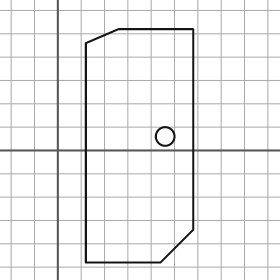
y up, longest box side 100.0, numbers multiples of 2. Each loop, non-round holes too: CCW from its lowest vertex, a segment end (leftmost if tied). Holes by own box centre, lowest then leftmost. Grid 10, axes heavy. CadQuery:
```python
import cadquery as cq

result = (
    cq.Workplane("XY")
    .moveTo(12.0, -48.0)
    .lineTo(44.0, -48.0)
    .lineTo(58.0, -34.0)
    .lineTo(58.0, 52.0)
    .lineTo(26.0, 52.0)
    .lineTo(12.0, 46.0)
    .close()
    .moveTo(46.0, 6.0)
    .circle(4.0)
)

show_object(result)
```